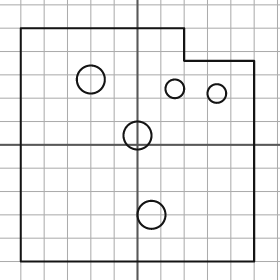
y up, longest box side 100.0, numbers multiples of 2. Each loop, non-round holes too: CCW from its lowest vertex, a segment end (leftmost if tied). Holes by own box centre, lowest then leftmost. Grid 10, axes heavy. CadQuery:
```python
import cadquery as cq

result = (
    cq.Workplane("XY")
    .moveTo(-50.0, -50.0)
    .lineTo(50.0, -50.0)
    .lineTo(50.0, 36.0)
    .lineTo(20.0, 36.0)
    .lineTo(20.0, 50.0)
    .lineTo(-50.0, 50.0)
    .close()
    .moveTo(6.0, -30.0)
    .circle(6.0)
    .moveTo(0.0, 4.0)
    .circle(6.0)
    .moveTo(34.0, 22.0)
    .circle(4.0)
    .moveTo(16.0, 24.0)
    .circle(4.0)
    .moveTo(-20.0, 28.0)
    .circle(6.0)
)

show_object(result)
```